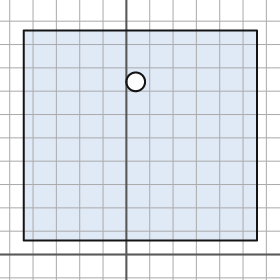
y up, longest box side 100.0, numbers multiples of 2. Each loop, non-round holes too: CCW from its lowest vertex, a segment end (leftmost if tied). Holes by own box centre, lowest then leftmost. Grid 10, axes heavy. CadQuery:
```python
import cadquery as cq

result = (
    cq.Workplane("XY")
    .moveTo(-44.0, 6.0)
    .lineTo(56.0, 6.0)
    .lineTo(56.0, 96.0)
    .lineTo(-44.0, 96.0)
    .close()
    .moveTo(4.0, 74.0)
    .circle(4.0)
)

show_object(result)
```